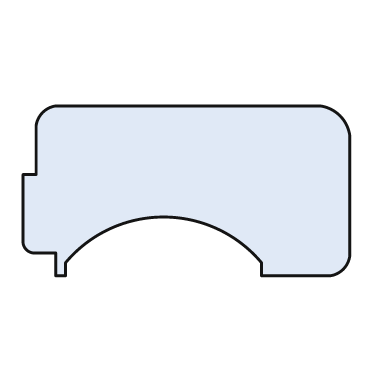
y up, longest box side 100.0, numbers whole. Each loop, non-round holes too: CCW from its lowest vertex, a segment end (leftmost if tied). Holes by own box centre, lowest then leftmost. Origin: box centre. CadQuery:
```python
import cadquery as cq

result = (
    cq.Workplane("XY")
    .moveTo(-40.0, -26.0)
    .lineTo(-37.0, -26.0)
    .lineTo(-37.0, -22.0)
    .threePointArc((-7.0, -8.0), (23.0, -22.0))
    .lineTo(23.0, -26.0)
    .lineTo(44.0, -26.0)
    .threePointArc((48.0, -24.0), (50.0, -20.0))
    .lineTo(50.0, 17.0)
    .threePointArc((47.0, 23.0), (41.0, 26.0))
    .lineTo(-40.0, 26.0)
    .threePointArc((-44.0, 24.0), (-46.0, 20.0))
    .lineTo(-46.0, 5.0)
    .lineTo(-50.0, 5.0)
    .lineTo(-50.0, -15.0)
    .threePointArc((-49.0, -18.0), (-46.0, -19.0))
    .lineTo(-40.0, -19.0)
    .close()
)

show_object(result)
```